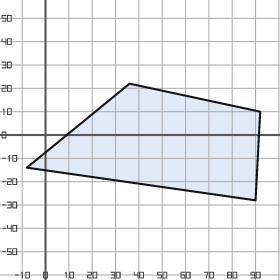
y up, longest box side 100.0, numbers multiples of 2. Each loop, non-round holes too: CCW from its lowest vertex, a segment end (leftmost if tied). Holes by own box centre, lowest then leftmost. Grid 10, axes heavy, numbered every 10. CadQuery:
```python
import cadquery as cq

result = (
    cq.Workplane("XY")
    .moveTo(90.0, -28.0)
    .lineTo(92.0, 10.0)
    .lineTo(36.0, 22.0)
    .lineTo(-8.0, -14.0)
    .close()
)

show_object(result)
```